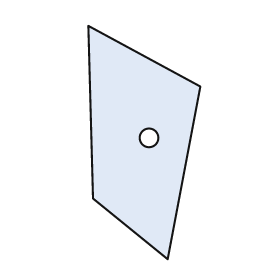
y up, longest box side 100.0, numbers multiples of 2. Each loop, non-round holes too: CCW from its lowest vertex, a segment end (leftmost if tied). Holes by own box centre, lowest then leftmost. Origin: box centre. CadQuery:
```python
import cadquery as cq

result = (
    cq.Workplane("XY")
    .moveTo(10.0, -50.0)
    .lineTo(24.0, 24.0)
    .lineTo(-24.0, 50.0)
    .lineTo(-22.0, -24.0)
    .close()
    .moveTo(2.0, 2.0)
    .circle(4.0)
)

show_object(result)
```